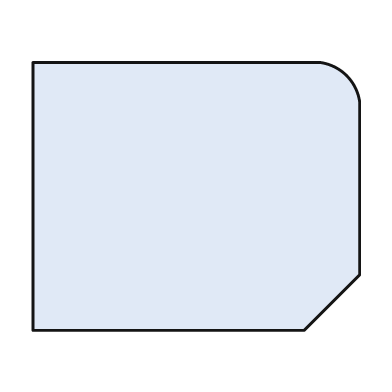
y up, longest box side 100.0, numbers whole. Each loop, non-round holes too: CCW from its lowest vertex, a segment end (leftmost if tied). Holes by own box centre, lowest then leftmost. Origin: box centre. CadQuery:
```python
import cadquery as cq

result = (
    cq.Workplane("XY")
    .moveTo(-50.0, -41.0)
    .lineTo(33.0, -41.0)
    .lineTo(50.0, -24.0)
    .lineTo(50.0, 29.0)
    .threePointArc((46.0, 37.0), (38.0, 41.0))
    .lineTo(-50.0, 41.0)
    .close()
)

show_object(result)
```